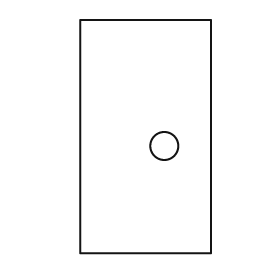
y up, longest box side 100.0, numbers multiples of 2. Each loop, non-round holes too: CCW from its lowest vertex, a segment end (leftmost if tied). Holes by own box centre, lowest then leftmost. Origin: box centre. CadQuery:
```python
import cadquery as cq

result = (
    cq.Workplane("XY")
    .moveTo(-28.0, -50.0)
    .lineTo(28.0, -50.0)
    .lineTo(28.0, 50.0)
    .lineTo(-28.0, 50.0)
    .close()
    .moveTo(8.0, -4.0)
    .circle(6.0)
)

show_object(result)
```